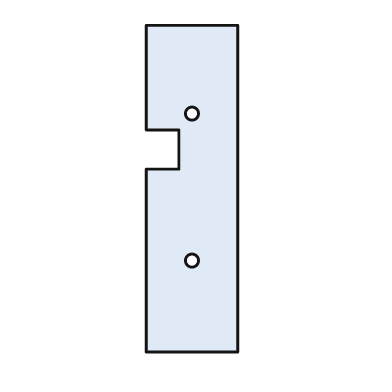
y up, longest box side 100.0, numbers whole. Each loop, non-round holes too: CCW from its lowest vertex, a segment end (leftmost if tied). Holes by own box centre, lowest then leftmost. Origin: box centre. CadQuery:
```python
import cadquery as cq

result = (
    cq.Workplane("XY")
    .moveTo(-14.0, -50.0)
    .lineTo(14.0, -50.0)
    .lineTo(14.0, 50.0)
    .lineTo(-14.0, 50.0)
    .lineTo(-14.0, 18.0)
    .lineTo(-4.0, 18.0)
    .lineTo(-4.0, 6.0)
    .lineTo(-14.0, 6.0)
    .close()
    .moveTo(0.0, -22.0)
    .circle(2.0)
    .moveTo(0.0, 23.0)
    .circle(2.0)
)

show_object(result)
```